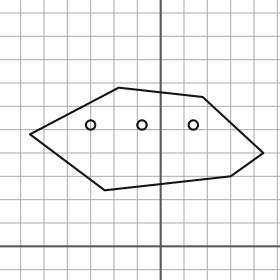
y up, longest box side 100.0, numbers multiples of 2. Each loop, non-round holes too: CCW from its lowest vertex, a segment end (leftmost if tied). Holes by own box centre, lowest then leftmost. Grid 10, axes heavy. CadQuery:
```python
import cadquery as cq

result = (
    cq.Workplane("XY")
    .moveTo(-24.0, 24.0)
    .lineTo(30.0, 30.0)
    .lineTo(44.0, 40.0)
    .lineTo(18.0, 64.0)
    .lineTo(-18.0, 68.0)
    .lineTo(-56.0, 48.0)
    .close()
    .moveTo(-30.0, 52.0)
    .circle(2.0)
    .moveTo(-8.0, 52.0)
    .circle(2.0)
    .moveTo(14.0, 52.0)
    .circle(2.0)
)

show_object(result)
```